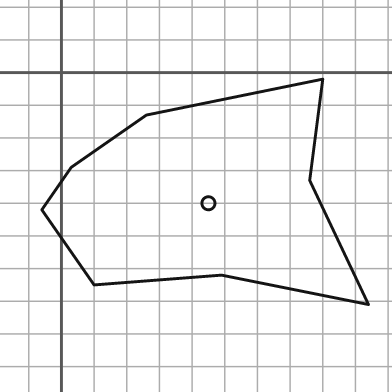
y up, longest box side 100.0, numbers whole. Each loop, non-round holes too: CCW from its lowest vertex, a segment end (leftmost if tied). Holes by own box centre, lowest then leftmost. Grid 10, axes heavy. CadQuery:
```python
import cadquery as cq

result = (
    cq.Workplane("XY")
    .moveTo(94.0, -71.0)
    .lineTo(76.0, -33.0)
    .lineTo(80.0, -2.0)
    .lineTo(26.0, -13.0)
    .lineTo(3.0, -29.0)
    .lineTo(-6.0, -42.0)
    .lineTo(10.0, -65.0)
    .lineTo(49.0, -62.0)
    .close()
    .moveTo(45.0, -40.0)
    .circle(2.0)
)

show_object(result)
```